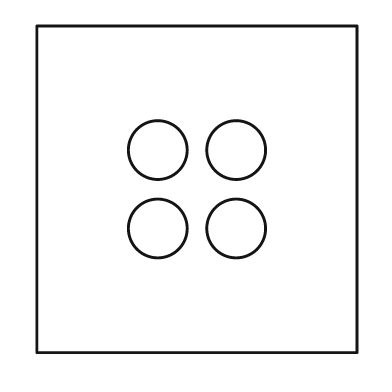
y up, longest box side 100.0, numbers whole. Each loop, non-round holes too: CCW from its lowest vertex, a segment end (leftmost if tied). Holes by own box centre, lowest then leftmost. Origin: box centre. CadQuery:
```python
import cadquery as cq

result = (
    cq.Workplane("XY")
    .moveTo(-49.0, -50.0)
    .lineTo(49.0, -50.0)
    .lineTo(49.0, 50.0)
    .lineTo(-49.0, 50.0)
    .close()
    .moveTo(-12.0, -12.0)
    .circle(9.0)
    .moveTo(12.0, -12.0)
    .circle(9.0)
    .moveTo(-12.0, 12.0)
    .circle(9.0)
    .moveTo(12.0, 12.0)
    .circle(9.0)
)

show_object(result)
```